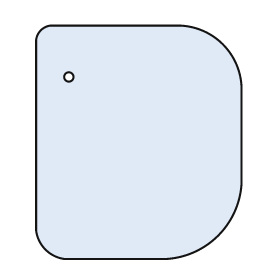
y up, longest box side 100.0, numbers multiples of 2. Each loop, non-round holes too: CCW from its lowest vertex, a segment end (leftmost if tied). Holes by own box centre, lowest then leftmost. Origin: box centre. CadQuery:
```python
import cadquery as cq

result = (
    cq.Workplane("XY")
    .moveTo(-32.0, -50.0)
    .lineTo(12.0, -50.0)
    .threePointArc((34.0, -40.0), (44.0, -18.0))
    .lineTo(44.0, 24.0)
    .threePointArc((36.0, 42.0), (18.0, 50.0))
    .lineTo(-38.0, 50.0)
    .threePointArc((-42.0, 48.0), (-44.0, 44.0))
    .lineTo(-44.0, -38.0)
    .threePointArc((-40.0, -46.0), (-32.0, -50.0))
    .close()
    .moveTo(-30.0, 28.0)
    .circle(2.0)
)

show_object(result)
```